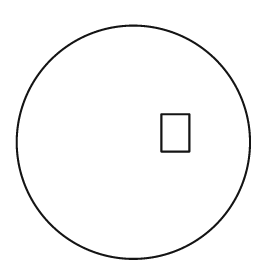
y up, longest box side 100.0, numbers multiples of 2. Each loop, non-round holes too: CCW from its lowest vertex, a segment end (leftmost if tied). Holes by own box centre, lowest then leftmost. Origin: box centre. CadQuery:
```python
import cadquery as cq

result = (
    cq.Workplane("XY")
    .moveTo(0.0, 0.0)
    .circle(50.0)
    .moveTo(12.0, -4.0)
    .lineTo(24.0, -4.0)
    .lineTo(24.0, 12.0)
    .lineTo(12.0, 12.0)
    .close()
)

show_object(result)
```